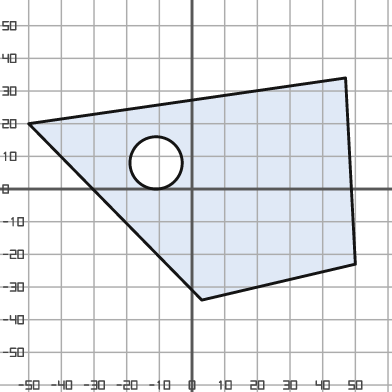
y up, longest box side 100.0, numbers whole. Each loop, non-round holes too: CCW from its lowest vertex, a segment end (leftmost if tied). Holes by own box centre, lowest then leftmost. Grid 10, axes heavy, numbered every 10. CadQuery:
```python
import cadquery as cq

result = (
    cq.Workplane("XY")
    .moveTo(3.0, -34.0)
    .lineTo(50.0, -23.0)
    .lineTo(47.0, 34.0)
    .lineTo(-50.0, 20.0)
    .close()
    .moveTo(-11.0, 8.0)
    .circle(8.0)
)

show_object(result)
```